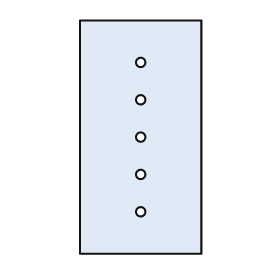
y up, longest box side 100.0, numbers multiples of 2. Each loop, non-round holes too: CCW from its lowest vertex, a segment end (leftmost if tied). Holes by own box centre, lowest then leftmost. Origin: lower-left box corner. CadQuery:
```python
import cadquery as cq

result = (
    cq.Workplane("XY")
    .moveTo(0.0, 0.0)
    .lineTo(52.0, 0.0)
    .lineTo(52.0, 100.0)
    .lineTo(0.0, 100.0)
    .close()
    .moveTo(26.0, 18.0)
    .circle(2.0)
    .moveTo(26.0, 34.0)
    .circle(2.0)
    .moveTo(26.0, 50.0)
    .circle(2.0)
    .moveTo(26.0, 66.0)
    .circle(2.0)
    .moveTo(26.0, 82.0)
    .circle(2.0)
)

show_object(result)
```